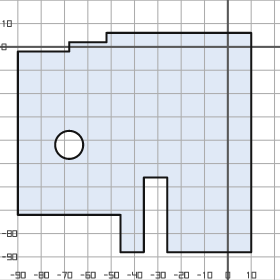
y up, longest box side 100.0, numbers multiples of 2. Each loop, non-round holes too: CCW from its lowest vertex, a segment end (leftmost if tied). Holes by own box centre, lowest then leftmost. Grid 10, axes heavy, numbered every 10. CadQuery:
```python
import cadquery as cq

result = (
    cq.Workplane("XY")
    .moveTo(-46.0, -88.0)
    .lineTo(-36.0, -88.0)
    .lineTo(-36.0, -56.0)
    .lineTo(-26.0, -56.0)
    .lineTo(-26.0, -88.0)
    .lineTo(10.0, -88.0)
    .lineTo(10.0, 6.0)
    .lineTo(-52.0, 6.0)
    .lineTo(-52.0, 2.0)
    .lineTo(-68.0, 2.0)
    .lineTo(-68.0, -2.0)
    .lineTo(-90.0, -2.0)
    .lineTo(-90.0, -72.0)
    .lineTo(-46.0, -72.0)
    .close()
    .moveTo(-68.0, -42.0)
    .circle(6.0)
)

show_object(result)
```